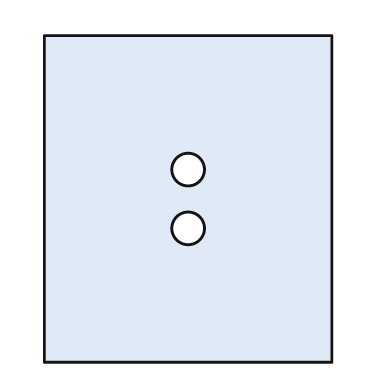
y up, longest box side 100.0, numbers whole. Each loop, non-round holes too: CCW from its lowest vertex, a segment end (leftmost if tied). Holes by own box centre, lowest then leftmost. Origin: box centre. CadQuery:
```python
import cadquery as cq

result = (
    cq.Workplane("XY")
    .moveTo(-44.0, -50.0)
    .lineTo(44.0, -50.0)
    .lineTo(44.0, 50.0)
    .lineTo(-44.0, 50.0)
    .close()
    .moveTo(0.0, -9.0)
    .circle(5.0)
    .moveTo(0.0, 9.0)
    .circle(5.0)
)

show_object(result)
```